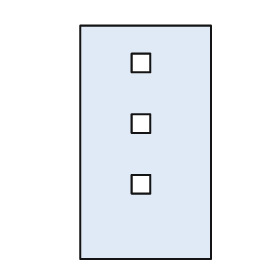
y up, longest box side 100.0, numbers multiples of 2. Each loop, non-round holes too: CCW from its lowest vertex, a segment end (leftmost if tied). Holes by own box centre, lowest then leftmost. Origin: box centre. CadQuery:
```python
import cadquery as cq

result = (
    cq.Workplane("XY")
    .moveTo(-28.0, -50.0)
    .lineTo(28.0, -50.0)
    .lineTo(28.0, 50.0)
    .lineTo(-28.0, 50.0)
    .close()
    .moveTo(-6.0, -22.0)
    .lineTo(2.0, -22.0)
    .lineTo(2.0, -14.0)
    .lineTo(-6.0, -14.0)
    .close()
    .moveTo(-6.0, 4.0)
    .lineTo(2.0, 4.0)
    .lineTo(2.0, 12.0)
    .lineTo(-6.0, 12.0)
    .close()
    .moveTo(-6.0, 30.0)
    .lineTo(2.0, 30.0)
    .lineTo(2.0, 38.0)
    .lineTo(-6.0, 38.0)
    .close()
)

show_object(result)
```